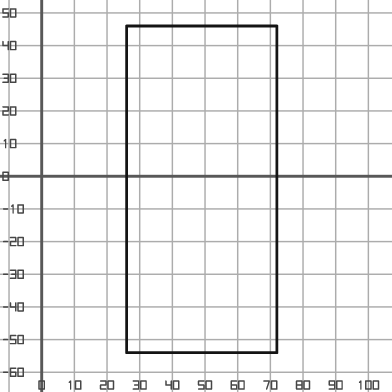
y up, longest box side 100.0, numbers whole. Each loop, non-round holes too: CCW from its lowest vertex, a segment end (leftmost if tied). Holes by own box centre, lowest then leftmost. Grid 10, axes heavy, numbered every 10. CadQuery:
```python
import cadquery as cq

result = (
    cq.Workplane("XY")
    .moveTo(26.0, -54.0)
    .lineTo(72.0, -54.0)
    .lineTo(72.0, 46.0)
    .lineTo(26.0, 46.0)
    .close()
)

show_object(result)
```